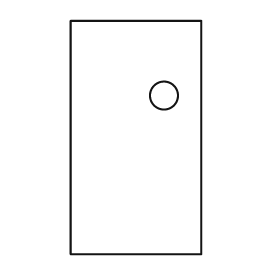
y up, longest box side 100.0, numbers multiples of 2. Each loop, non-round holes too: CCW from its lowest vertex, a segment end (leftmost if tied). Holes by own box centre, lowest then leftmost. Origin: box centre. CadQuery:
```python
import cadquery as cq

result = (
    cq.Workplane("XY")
    .moveTo(-28.0, -50.0)
    .lineTo(28.0, -50.0)
    .lineTo(28.0, 50.0)
    .lineTo(-28.0, 50.0)
    .close()
    .moveTo(12.0, 18.0)
    .circle(6.0)
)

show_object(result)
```